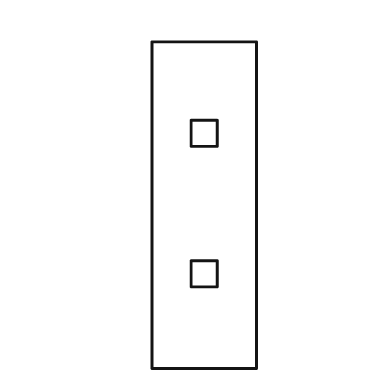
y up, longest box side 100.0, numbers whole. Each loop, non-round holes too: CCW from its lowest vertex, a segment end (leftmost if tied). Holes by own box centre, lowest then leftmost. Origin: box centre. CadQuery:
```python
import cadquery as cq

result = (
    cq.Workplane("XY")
    .moveTo(-16.0, -50.0)
    .lineTo(16.0, -50.0)
    .lineTo(16.0, 50.0)
    .lineTo(-16.0, 50.0)
    .close()
    .moveTo(-4.0, -25.0)
    .lineTo(4.0, -25.0)
    .lineTo(4.0, -17.0)
    .lineTo(-4.0, -17.0)
    .close()
    .moveTo(-4.0, 18.0)
    .lineTo(4.0, 18.0)
    .lineTo(4.0, 26.0)
    .lineTo(-4.0, 26.0)
    .close()
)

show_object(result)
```